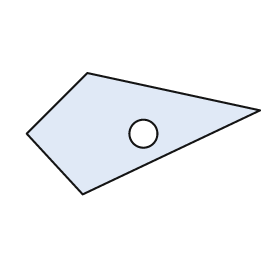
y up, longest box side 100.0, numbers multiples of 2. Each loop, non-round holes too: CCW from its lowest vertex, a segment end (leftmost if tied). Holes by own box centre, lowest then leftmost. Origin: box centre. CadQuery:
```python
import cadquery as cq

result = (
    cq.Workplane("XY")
    .moveTo(-26.0, -26.0)
    .lineTo(50.0, 10.0)
    .lineTo(-24.0, 26.0)
    .lineTo(-50.0, 0.0)
    .close()
    .moveTo(0.0, 0.0)
    .circle(6.0)
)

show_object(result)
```